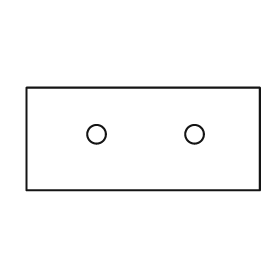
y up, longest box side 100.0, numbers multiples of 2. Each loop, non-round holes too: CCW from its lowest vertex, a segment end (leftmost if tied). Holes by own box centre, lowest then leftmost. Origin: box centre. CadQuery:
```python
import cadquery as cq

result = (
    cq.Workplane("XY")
    .moveTo(-50.0, -22.0)
    .lineTo(50.0, -22.0)
    .lineTo(50.0, 22.0)
    .lineTo(-50.0, 22.0)
    .close()
    .moveTo(-20.0, 2.0)
    .circle(4.0)
    .moveTo(22.0, 2.0)
    .circle(4.0)
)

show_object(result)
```